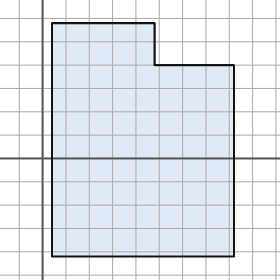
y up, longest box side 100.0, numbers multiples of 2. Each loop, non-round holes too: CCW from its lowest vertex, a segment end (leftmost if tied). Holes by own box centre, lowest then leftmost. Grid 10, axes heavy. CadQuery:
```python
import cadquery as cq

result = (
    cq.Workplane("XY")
    .moveTo(4.0, -42.0)
    .lineTo(82.0, -42.0)
    .lineTo(82.0, 40.0)
    .lineTo(48.0, 40.0)
    .lineTo(48.0, 58.0)
    .lineTo(4.0, 58.0)
    .close()
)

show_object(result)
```